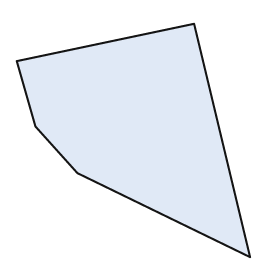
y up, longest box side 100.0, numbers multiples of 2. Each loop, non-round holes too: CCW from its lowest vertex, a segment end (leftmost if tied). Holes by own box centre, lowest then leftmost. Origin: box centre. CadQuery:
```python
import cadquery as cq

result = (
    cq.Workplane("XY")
    .moveTo(50.0, -50.0)
    .lineTo(26.0, 50.0)
    .lineTo(-50.0, 34.0)
    .lineTo(-42.0, 6.0)
    .lineTo(-24.0, -14.0)
    .close()
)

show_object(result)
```